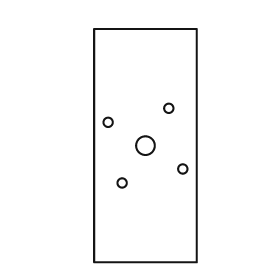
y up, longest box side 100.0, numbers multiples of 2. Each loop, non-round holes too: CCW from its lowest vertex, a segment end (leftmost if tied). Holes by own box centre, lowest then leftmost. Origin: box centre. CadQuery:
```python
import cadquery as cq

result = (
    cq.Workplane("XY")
    .moveTo(-22.0, -50.0)
    .lineTo(22.0, -50.0)
    .lineTo(22.0, 50.0)
    .lineTo(-22.0, 50.0)
    .close()
    .moveTo(-10.0, -16.0)
    .circle(2.0)
    .moveTo(16.0, -10.0)
    .circle(2.0)
    .moveTo(0.0, 0.0)
    .circle(4.0)
    .moveTo(-16.0, 10.0)
    .circle(2.0)
    .moveTo(10.0, 16.0)
    .circle(2.0)
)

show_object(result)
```